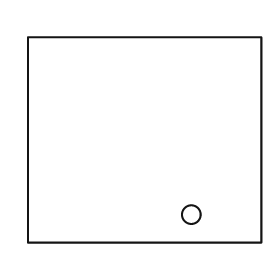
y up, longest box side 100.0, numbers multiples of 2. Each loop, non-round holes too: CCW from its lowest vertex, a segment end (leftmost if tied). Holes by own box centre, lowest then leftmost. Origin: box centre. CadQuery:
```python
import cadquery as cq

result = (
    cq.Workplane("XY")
    .moveTo(-50.0, -44.0)
    .lineTo(50.0, -44.0)
    .lineTo(50.0, 44.0)
    .lineTo(-50.0, 44.0)
    .close()
    .moveTo(20.0, -32.0)
    .circle(4.0)
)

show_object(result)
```